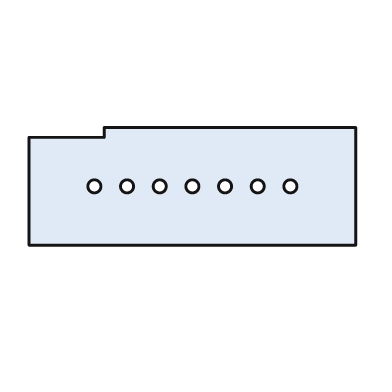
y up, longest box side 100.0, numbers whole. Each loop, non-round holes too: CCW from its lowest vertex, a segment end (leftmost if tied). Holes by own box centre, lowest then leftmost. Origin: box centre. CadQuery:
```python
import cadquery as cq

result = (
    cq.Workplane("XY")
    .moveTo(-50.0, -18.0)
    .lineTo(50.0, -18.0)
    .lineTo(50.0, 18.0)
    .lineTo(-27.0, 18.0)
    .lineTo(-27.0, 15.0)
    .lineTo(-50.0, 15.0)
    .close()
    .moveTo(-30.0, 0.0)
    .circle(2.0)
    .moveTo(-20.0, 0.0)
    .circle(2.0)
    .moveTo(-10.0, 0.0)
    .circle(2.0)
    .moveTo(0.0, 0.0)
    .circle(2.0)
    .moveTo(10.0, 0.0)
    .circle(2.0)
    .moveTo(20.0, 0.0)
    .circle(2.0)
    .moveTo(30.0, 0.0)
    .circle(2.0)
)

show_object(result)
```